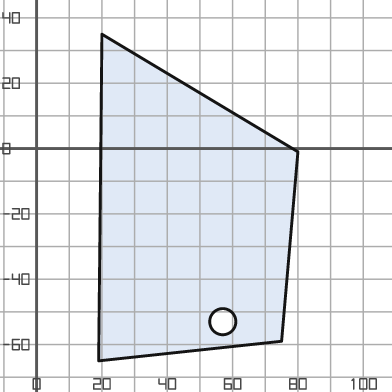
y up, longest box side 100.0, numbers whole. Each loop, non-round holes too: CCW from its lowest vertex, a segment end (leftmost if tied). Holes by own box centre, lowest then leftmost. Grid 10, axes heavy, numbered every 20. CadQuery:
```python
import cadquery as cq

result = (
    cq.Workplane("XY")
    .moveTo(19.0, -65.0)
    .lineTo(75.0, -59.0)
    .lineTo(80.0, -1.0)
    .lineTo(20.0, 35.0)
    .close()
    .moveTo(57.0, -53.0)
    .circle(4.0)
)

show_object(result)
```